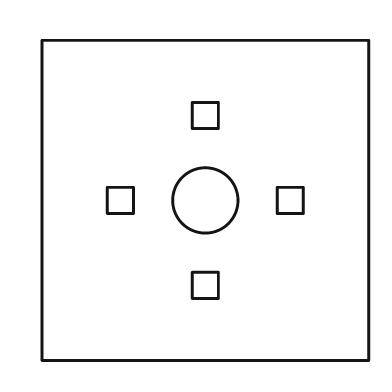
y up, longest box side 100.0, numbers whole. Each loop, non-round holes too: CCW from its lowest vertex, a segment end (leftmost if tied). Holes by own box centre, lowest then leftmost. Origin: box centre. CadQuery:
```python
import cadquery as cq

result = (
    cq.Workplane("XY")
    .moveTo(-50.0, -49.0)
    .lineTo(50.0, -49.0)
    .lineTo(50.0, 49.0)
    .lineTo(-50.0, 49.0)
    .close()
    .moveTo(-4.0, -30.0)
    .lineTo(4.0, -30.0)
    .lineTo(4.0, -22.0)
    .lineTo(-4.0, -22.0)
    .close()
    .moveTo(-30.0, -4.0)
    .lineTo(-22.0, -4.0)
    .lineTo(-22.0, 4.0)
    .lineTo(-30.0, 4.0)
    .close()
    .moveTo(0.0, 0.0)
    .circle(10.0)
    .moveTo(22.0, -4.0)
    .lineTo(30.0, -4.0)
    .lineTo(30.0, 4.0)
    .lineTo(22.0, 4.0)
    .close()
    .moveTo(-4.0, 22.0)
    .lineTo(4.0, 22.0)
    .lineTo(4.0, 30.0)
    .lineTo(-4.0, 30.0)
    .close()
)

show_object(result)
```